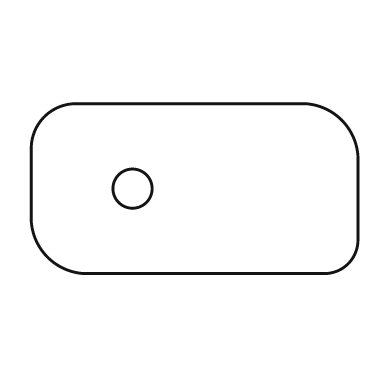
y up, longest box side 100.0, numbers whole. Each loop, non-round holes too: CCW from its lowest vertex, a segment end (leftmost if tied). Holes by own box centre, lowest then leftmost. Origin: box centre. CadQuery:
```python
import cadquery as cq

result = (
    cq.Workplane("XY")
    .moveTo(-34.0, -26.0)
    .lineTo(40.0, -26.0)
    .threePointArc((47.0, -23.0), (50.0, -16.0))
    .lineTo(50.0, 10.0)
    .threePointArc((45.0, 21.0), (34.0, 26.0))
    .lineTo(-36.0, 26.0)
    .threePointArc((-46.0, 22.0), (-50.0, 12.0))
    .lineTo(-50.0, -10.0)
    .threePointArc((-45.0, -21.0), (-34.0, -26.0))
    .close()
    .moveTo(-19.0, 0.0)
    .circle(6.0)
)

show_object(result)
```